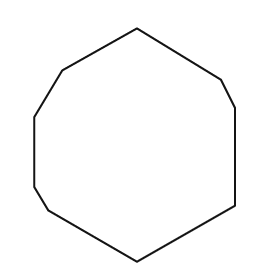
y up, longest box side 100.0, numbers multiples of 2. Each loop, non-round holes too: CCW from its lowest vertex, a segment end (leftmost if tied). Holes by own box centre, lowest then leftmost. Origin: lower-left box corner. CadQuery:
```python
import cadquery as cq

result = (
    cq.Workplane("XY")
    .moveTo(44.0, 0.0)
    .lineTo(86.0, 24.0)
    .lineTo(86.0, 66.0)
    .lineTo(80.0, 78.0)
    .lineTo(44.0, 100.0)
    .lineTo(12.0, 82.0)
    .lineTo(0.0, 62.0)
    .lineTo(0.0, 32.0)
    .lineTo(6.0, 22.0)
    .close()
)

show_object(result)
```